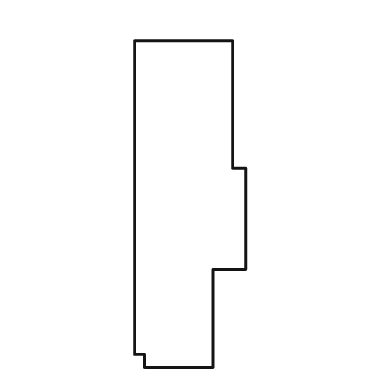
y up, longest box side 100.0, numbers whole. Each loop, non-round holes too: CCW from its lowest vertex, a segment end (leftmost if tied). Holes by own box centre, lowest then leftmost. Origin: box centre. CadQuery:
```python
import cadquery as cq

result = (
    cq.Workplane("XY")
    .moveTo(-14.0, -50.0)
    .lineTo(7.0, -50.0)
    .lineTo(7.0, -20.0)
    .lineTo(17.0, -20.0)
    .lineTo(17.0, 11.0)
    .lineTo(13.0, 11.0)
    .lineTo(13.0, 50.0)
    .lineTo(-17.0, 50.0)
    .lineTo(-17.0, -46.0)
    .lineTo(-14.0, -46.0)
    .close()
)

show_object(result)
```